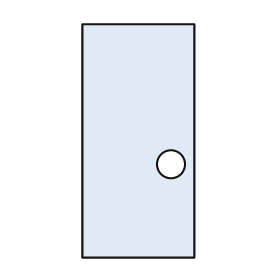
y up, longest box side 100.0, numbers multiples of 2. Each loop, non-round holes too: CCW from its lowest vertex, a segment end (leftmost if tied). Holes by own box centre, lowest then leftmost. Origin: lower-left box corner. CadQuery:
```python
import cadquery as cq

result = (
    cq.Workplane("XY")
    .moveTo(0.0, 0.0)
    .lineTo(48.0, 0.0)
    .lineTo(48.0, 100.0)
    .lineTo(0.0, 100.0)
    .close()
    .moveTo(38.0, 40.0)
    .circle(6.0)
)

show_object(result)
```